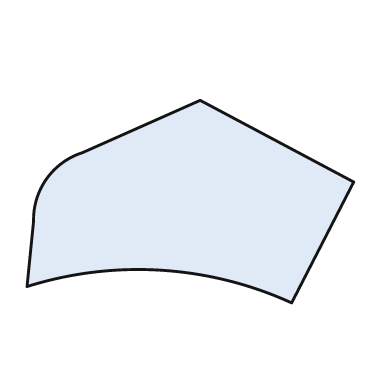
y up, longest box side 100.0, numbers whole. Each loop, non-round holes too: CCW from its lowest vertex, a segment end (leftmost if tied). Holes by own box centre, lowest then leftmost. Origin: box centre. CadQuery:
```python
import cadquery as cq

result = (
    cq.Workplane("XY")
    .moveTo(31.0, -31.0)
    .lineTo(50.0, 6.0)
    .lineTo(3.0, 31.0)
    .lineTo(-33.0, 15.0)
    .threePointArc((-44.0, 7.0), (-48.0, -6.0))
    .lineTo(-50.0, -26.0)
    .threePointArc((-9.0, -21.0), (31.0, -31.0))
    .close()
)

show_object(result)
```